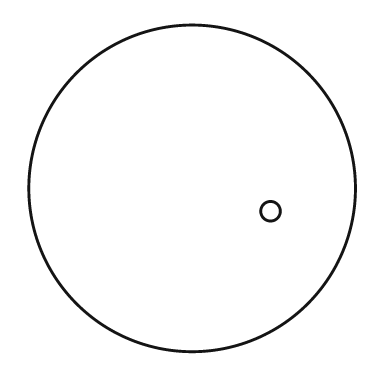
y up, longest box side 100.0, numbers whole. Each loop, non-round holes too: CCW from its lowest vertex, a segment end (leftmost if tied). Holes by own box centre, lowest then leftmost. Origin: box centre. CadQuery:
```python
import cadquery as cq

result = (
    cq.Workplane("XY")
    .moveTo(0.0, 0.0)
    .circle(50.0)
    .moveTo(24.0, -7.0)
    .circle(3.0)
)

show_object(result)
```